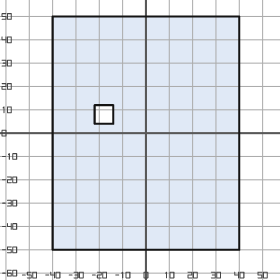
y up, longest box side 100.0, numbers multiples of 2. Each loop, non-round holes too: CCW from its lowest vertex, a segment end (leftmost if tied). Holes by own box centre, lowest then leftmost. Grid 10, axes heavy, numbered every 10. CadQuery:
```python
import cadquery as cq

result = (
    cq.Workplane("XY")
    .moveTo(-40.0, -50.0)
    .lineTo(40.0, -50.0)
    .lineTo(40.0, 50.0)
    .lineTo(-40.0, 50.0)
    .close()
    .moveTo(-22.0, 4.0)
    .lineTo(-14.0, 4.0)
    .lineTo(-14.0, 12.0)
    .lineTo(-22.0, 12.0)
    .close()
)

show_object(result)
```